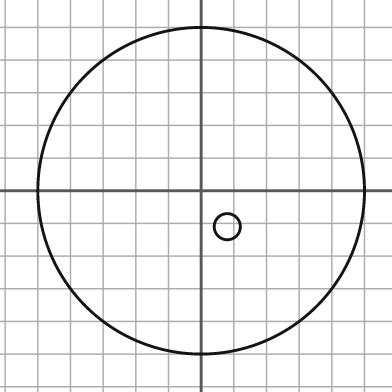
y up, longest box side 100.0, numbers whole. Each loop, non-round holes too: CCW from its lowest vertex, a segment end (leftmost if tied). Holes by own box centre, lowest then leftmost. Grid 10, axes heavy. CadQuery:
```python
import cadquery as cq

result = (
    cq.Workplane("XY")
    .moveTo(0.0, 0.0)
    .circle(50.0)
    .moveTo(8.0, -11.0)
    .circle(4.0)
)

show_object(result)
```